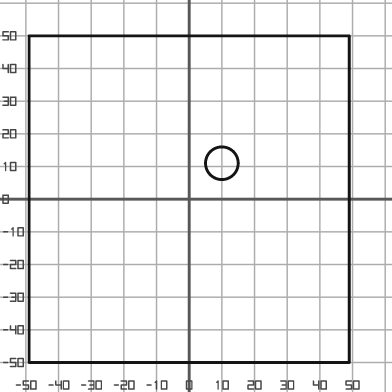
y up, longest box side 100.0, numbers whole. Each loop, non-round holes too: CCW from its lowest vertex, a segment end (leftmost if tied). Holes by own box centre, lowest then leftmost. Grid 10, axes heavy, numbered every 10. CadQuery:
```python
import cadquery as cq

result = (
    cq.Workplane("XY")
    .moveTo(-49.0, -50.0)
    .lineTo(49.0, -50.0)
    .lineTo(49.0, 50.0)
    .lineTo(-49.0, 50.0)
    .close()
    .moveTo(10.0, 11.0)
    .circle(5.0)
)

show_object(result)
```